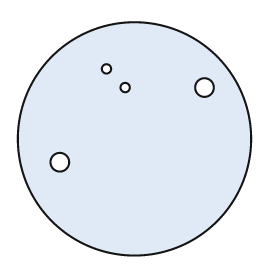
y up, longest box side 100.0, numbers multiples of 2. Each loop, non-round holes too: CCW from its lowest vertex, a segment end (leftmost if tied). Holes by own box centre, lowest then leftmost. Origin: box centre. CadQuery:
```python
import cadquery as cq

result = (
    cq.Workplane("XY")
    .moveTo(0.0, 0.0)
    .circle(50.0)
    .moveTo(-32.0, -10.0)
    .circle(4.0)
    .moveTo(-4.0, 22.0)
    .circle(2.0)
    .moveTo(30.0, 22.0)
    .circle(4.0)
    .moveTo(-12.0, 30.0)
    .circle(2.0)
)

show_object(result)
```